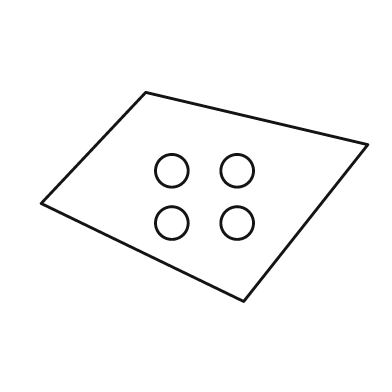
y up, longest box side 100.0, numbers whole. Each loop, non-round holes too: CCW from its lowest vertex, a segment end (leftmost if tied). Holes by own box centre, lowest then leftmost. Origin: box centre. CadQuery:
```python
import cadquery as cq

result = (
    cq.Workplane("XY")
    .moveTo(12.0, -32.0)
    .lineTo(50.0, 16.0)
    .lineTo(-18.0, 32.0)
    .lineTo(-50.0, -2.0)
    .close()
    .moveTo(-10.0, -8.0)
    .circle(5.0)
    .moveTo(10.0, -8.0)
    .circle(5.0)
    .moveTo(-10.0, 8.0)
    .circle(5.0)
    .moveTo(10.0, 8.0)
    .circle(5.0)
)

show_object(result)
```